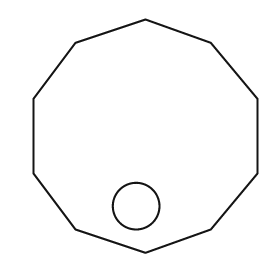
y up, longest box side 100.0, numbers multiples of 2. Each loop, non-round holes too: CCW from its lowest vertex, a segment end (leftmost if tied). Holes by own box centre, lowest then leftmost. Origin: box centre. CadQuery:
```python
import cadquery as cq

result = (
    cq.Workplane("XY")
    .moveTo(0.0, -50.0)
    .lineTo(28.0, -40.0)
    .lineTo(48.0, -16.0)
    .lineTo(48.0, 16.0)
    .lineTo(28.0, 40.0)
    .lineTo(0.0, 50.0)
    .lineTo(-30.0, 40.0)
    .lineTo(-48.0, 16.0)
    .lineTo(-48.0, -16.0)
    .lineTo(-30.0, -40.0)
    .close()
    .moveTo(-4.0, -30.0)
    .circle(10.0)
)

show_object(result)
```